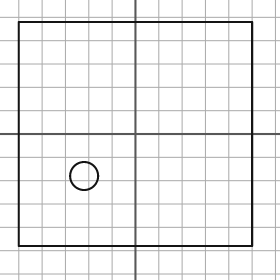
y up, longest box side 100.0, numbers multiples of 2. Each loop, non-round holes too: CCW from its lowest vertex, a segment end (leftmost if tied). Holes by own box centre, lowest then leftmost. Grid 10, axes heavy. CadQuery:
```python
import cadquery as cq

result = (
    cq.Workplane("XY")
    .moveTo(-50.0, -48.0)
    .lineTo(50.0, -48.0)
    .lineTo(50.0, 48.0)
    .lineTo(-50.0, 48.0)
    .close()
    .moveTo(-22.0, -18.0)
    .circle(6.0)
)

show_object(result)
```